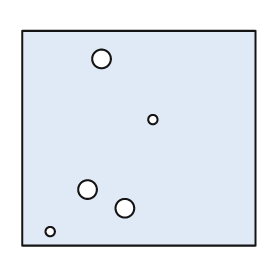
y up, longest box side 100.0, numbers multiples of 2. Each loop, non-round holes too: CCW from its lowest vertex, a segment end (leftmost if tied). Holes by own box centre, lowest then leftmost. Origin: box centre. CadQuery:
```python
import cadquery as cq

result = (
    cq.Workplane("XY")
    .moveTo(-50.0, -46.0)
    .lineTo(50.0, -46.0)
    .lineTo(50.0, 46.0)
    .lineTo(-50.0, 46.0)
    .close()
    .moveTo(-38.0, -40.0)
    .circle(2.0)
    .moveTo(-6.0, -30.0)
    .circle(4.0)
    .moveTo(-22.0, -22.0)
    .circle(4.0)
    .moveTo(6.0, 8.0)
    .circle(2.0)
    .moveTo(-16.0, 34.0)
    .circle(4.0)
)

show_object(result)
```